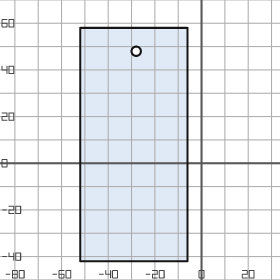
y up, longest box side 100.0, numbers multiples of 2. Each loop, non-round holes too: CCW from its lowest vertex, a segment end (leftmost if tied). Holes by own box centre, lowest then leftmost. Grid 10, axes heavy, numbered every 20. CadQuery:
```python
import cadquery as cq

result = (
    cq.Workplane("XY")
    .moveTo(-52.0, -42.0)
    .lineTo(-6.0, -42.0)
    .lineTo(-6.0, 58.0)
    .lineTo(-52.0, 58.0)
    .close()
    .moveTo(-28.0, 48.0)
    .circle(2.0)
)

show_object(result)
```